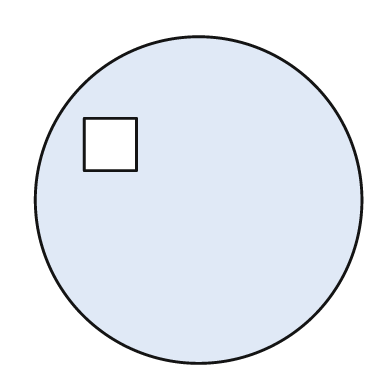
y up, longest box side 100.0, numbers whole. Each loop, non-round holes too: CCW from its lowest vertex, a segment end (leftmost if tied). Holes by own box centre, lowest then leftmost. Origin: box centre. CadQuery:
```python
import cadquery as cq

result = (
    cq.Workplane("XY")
    .moveTo(0.0, 0.0)
    .circle(50.0)
    .moveTo(-35.0, 9.0)
    .lineTo(-19.0, 9.0)
    .lineTo(-19.0, 25.0)
    .lineTo(-35.0, 25.0)
    .close()
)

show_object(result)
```